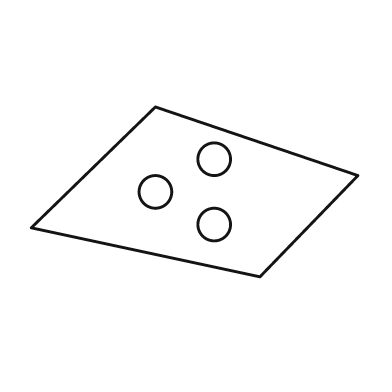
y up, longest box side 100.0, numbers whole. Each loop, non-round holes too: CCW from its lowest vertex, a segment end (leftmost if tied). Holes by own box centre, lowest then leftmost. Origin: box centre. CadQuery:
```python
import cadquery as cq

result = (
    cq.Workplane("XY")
    .moveTo(20.0, -26.0)
    .lineTo(50.0, 5.0)
    .lineTo(-12.0, 26.0)
    .lineTo(-50.0, -11.0)
    .close()
    .moveTo(6.0, -10.0)
    .circle(5.0)
    .moveTo(-12.0, 0.0)
    .circle(5.0)
    .moveTo(6.0, 10.0)
    .circle(5.0)
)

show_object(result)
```